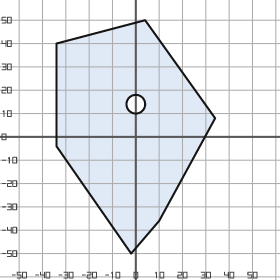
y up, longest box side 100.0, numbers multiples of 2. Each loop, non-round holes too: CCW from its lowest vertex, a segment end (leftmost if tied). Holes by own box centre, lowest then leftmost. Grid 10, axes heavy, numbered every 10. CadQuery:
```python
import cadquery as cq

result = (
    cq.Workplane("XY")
    .moveTo(-2.0, -50.0)
    .lineTo(10.0, -36.0)
    .lineTo(34.0, 8.0)
    .lineTo(4.0, 50.0)
    .lineTo(-34.0, 40.0)
    .lineTo(-34.0, -4.0)
    .close()
    .moveTo(0.0, 14.0)
    .circle(4.0)
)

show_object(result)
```